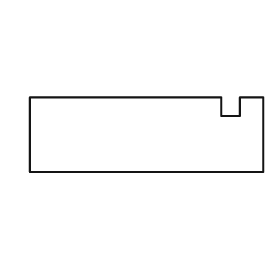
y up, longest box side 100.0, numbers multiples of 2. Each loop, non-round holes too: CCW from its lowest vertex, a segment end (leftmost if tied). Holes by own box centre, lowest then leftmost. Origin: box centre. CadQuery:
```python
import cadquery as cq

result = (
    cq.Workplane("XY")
    .moveTo(-50.0, -16.0)
    .lineTo(50.0, -16.0)
    .lineTo(50.0, 16.0)
    .lineTo(40.0, 16.0)
    .lineTo(40.0, 8.0)
    .lineTo(32.0, 8.0)
    .lineTo(32.0, 16.0)
    .lineTo(-50.0, 16.0)
    .close()
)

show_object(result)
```